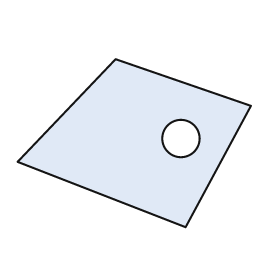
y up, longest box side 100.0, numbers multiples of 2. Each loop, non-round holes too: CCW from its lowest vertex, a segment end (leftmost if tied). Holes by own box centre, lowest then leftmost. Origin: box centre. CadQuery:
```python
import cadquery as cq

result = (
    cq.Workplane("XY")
    .moveTo(22.0, -36.0)
    .lineTo(50.0, 16.0)
    .lineTo(-8.0, 36.0)
    .lineTo(-50.0, -8.0)
    .close()
    .moveTo(20.0, 2.0)
    .circle(8.0)
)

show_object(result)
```